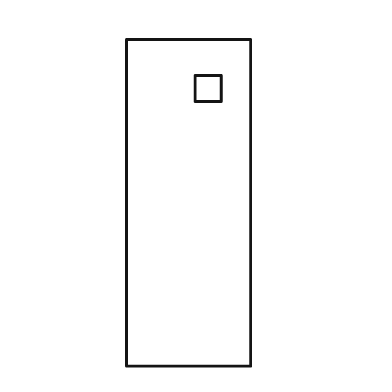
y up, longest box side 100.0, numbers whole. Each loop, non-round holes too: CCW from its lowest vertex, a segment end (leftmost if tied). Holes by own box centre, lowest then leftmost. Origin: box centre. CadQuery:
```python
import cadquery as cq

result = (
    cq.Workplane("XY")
    .moveTo(-19.0, -50.0)
    .lineTo(19.0, -50.0)
    .lineTo(19.0, 50.0)
    .lineTo(-19.0, 50.0)
    .close()
    .moveTo(2.0, 31.0)
    .lineTo(10.0, 31.0)
    .lineTo(10.0, 39.0)
    .lineTo(2.0, 39.0)
    .close()
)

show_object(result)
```